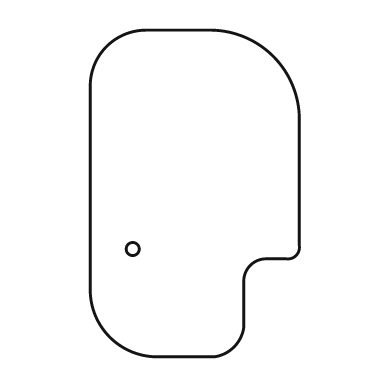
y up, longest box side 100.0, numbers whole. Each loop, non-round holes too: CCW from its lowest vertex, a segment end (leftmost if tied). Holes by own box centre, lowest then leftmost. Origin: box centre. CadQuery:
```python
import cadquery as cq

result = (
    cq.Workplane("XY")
    .moveTo(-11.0, -50.0)
    .lineTo(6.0, -50.0)
    .threePointArc((12.0, -47.0), (15.0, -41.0))
    .lineTo(15.0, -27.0)
    .threePointArc((17.0, -22.0), (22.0, -20.0))
    .lineTo(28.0, -20.0)
    .threePointArc((31.0, -19.0), (32.0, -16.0))
    .lineTo(32.0, 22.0)
    .threePointArc((24.0, 42.0), (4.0, 50.0))
    .lineTo(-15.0, 50.0)
    .threePointArc((-27.0, 45.0), (-32.0, 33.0))
    .lineTo(-32.0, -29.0)
    .threePointArc((-26.0, -44.0), (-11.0, -50.0))
    .close()
    .moveTo(-19.0, -17.0)
    .circle(2.0)
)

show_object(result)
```